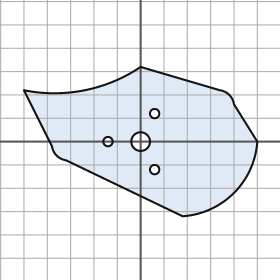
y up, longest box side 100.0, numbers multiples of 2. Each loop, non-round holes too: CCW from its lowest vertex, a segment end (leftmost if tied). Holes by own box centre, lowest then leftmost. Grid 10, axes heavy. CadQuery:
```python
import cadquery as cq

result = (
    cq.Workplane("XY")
    .moveTo(18.0, -32.0)
    .threePointArc((40.0, -22.0), (50.0, 0.0))
    .lineTo(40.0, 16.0)
    .threePointArc((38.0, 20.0), (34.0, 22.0))
    .lineTo(0.0, 32.0)
    .threePointArc((-24.0, 22.0), (-50.0, 22.0))
    .lineTo(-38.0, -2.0)
    .threePointArc((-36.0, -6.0), (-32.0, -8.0))
    .close()
    .moveTo(6.0, -12.0)
    .circle(2.0)
    .moveTo(-14.0, 0.0)
    .circle(2.0)
    .moveTo(0.0, 0.0)
    .circle(4.0)
    .moveTo(6.0, 12.0)
    .circle(2.0)
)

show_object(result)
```